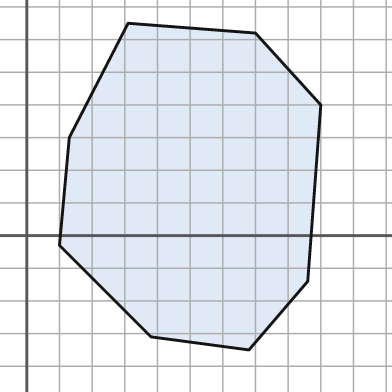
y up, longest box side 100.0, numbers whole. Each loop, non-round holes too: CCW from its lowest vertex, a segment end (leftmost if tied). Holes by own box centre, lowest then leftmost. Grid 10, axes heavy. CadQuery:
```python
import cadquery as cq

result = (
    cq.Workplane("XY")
    .moveTo(68.0, -35.0)
    .lineTo(86.0, -14.0)
    .lineTo(90.0, 40.0)
    .lineTo(70.0, 62.0)
    .lineTo(31.0, 65.0)
    .lineTo(13.0, 30.0)
    .lineTo(10.0, -3.0)
    .lineTo(38.0, -31.0)
    .close()
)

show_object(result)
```